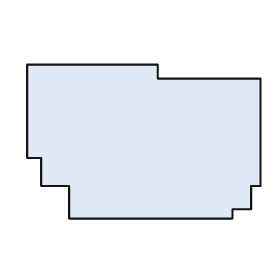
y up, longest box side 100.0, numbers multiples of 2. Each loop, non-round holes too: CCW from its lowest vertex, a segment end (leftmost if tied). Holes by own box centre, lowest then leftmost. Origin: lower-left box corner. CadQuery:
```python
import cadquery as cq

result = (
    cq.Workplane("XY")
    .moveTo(18.0, 0.0)
    .lineTo(88.0, 0.0)
    .lineTo(88.0, 4.0)
    .lineTo(96.0, 4.0)
    .lineTo(96.0, 14.0)
    .lineTo(100.0, 14.0)
    .lineTo(100.0, 60.0)
    .lineTo(56.0, 60.0)
    .lineTo(56.0, 66.0)
    .lineTo(0.0, 66.0)
    .lineTo(0.0, 26.0)
    .lineTo(6.0, 26.0)
    .lineTo(6.0, 14.0)
    .lineTo(18.0, 14.0)
    .close()
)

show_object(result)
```